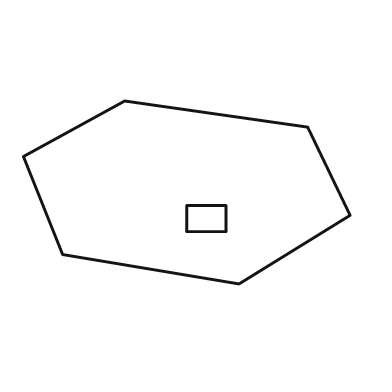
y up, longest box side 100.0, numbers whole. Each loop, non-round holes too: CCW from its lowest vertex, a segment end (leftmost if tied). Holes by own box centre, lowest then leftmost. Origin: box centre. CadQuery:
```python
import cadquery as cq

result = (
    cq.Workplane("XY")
    .moveTo(16.0, -28.0)
    .lineTo(50.0, -7.0)
    .lineTo(37.0, 20.0)
    .lineTo(-19.0, 28.0)
    .lineTo(-50.0, 11.0)
    .lineTo(-38.0, -19.0)
    .close()
    .moveTo(0.0, -12.0)
    .lineTo(12.0, -12.0)
    .lineTo(12.0, -4.0)
    .lineTo(0.0, -4.0)
    .close()
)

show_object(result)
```